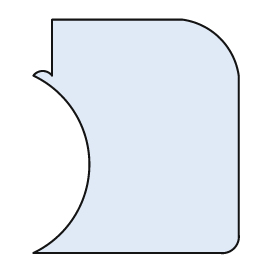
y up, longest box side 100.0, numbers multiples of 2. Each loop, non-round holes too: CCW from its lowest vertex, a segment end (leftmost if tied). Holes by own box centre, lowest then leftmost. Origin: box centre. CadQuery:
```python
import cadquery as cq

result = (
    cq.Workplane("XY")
    .moveTo(-44.0, -50.0)
    .lineTo(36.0, -50.0)
    .threePointArc((42.0, -48.0), (44.0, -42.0))
    .lineTo(44.0, 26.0)
    .threePointArc((36.0, 42.0), (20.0, 50.0))
    .lineTo(-36.0, 50.0)
    .lineTo(-36.0, 26.0)
    .threePointArc((-40.0, 28.0), (-44.0, 26.0))
    .threePointArc((-20.0, -12.0), (-44.0, -50.0))
    .close()
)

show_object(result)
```